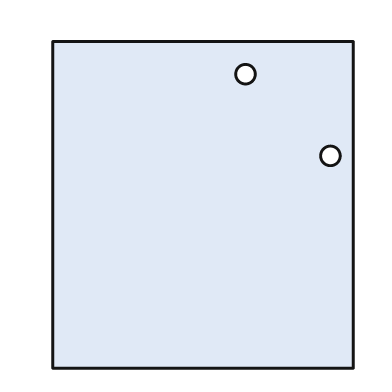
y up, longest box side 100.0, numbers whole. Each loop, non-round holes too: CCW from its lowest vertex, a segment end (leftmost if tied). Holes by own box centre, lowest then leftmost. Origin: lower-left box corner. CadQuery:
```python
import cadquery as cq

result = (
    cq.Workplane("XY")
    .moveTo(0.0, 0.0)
    .lineTo(92.0, 0.0)
    .lineTo(92.0, 100.0)
    .lineTo(0.0, 100.0)
    .close()
    .moveTo(85.0, 65.0)
    .circle(3.0)
    .moveTo(59.0, 90.0)
    .circle(3.0)
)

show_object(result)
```